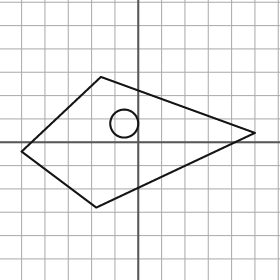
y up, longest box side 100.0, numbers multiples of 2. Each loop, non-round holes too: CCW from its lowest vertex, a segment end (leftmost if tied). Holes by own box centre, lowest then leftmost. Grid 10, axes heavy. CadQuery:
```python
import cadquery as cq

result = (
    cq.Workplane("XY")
    .moveTo(-18.0, -28.0)
    .lineTo(50.0, 4.0)
    .lineTo(-16.0, 28.0)
    .lineTo(-50.0, -4.0)
    .close()
    .moveTo(-6.0, 8.0)
    .circle(6.0)
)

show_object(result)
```